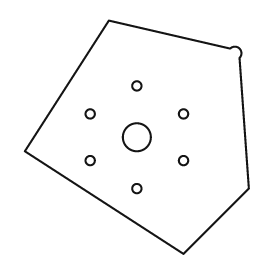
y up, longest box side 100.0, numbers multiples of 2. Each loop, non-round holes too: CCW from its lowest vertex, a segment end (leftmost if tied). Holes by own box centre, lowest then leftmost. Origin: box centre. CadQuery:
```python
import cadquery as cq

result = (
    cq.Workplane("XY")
    .moveTo(20.0, -50.0)
    .lineTo(48.0, -22.0)
    .lineTo(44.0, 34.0)
    .threePointArc((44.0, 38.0), (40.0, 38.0))
    .lineTo(-12.0, 50.0)
    .lineTo(-48.0, -6.0)
    .close()
    .moveTo(0.0, -22.0)
    .circle(2.0)
    .moveTo(-20.0, -10.0)
    .circle(2.0)
    .moveTo(20.0, -10.0)
    .circle(2.0)
    .moveTo(0.0, 0.0)
    .circle(6.0)
    .moveTo(-20.0, 10.0)
    .circle(2.0)
    .moveTo(20.0, 10.0)
    .circle(2.0)
    .moveTo(0.0, 22.0)
    .circle(2.0)
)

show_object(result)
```